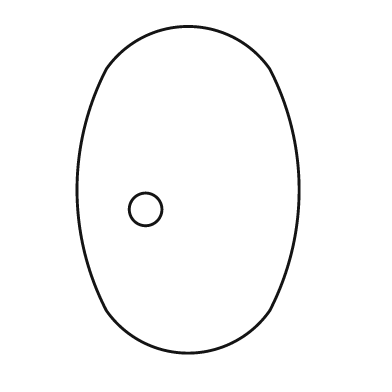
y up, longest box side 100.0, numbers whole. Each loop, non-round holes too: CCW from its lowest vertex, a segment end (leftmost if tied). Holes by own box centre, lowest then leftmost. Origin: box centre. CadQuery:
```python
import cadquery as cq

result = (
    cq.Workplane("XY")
    .moveTo(-25.0, -37.0)
    .threePointArc((0.0, -50.0), (25.0, -37.0))
    .threePointArc((34.0, 0.0), (25.0, 37.0))
    .threePointArc((0.0, 50.0), (-25.0, 37.0))
    .threePointArc((-34.0, 0.0), (-25.0, -37.0))
    .close()
    .moveTo(-13.0, -6.0)
    .circle(5.0)
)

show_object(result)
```